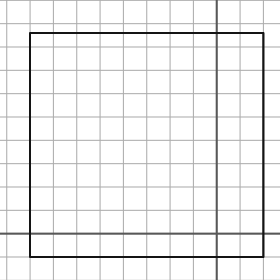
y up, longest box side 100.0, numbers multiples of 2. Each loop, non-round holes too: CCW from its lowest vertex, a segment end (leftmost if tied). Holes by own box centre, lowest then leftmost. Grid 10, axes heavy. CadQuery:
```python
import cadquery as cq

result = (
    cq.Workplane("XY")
    .moveTo(-80.0, -10.0)
    .lineTo(20.0, -10.0)
    .lineTo(20.0, 86.0)
    .lineTo(-80.0, 86.0)
    .close()
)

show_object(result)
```